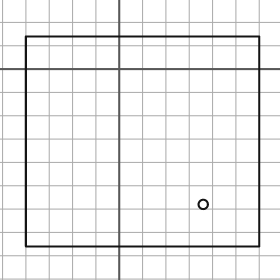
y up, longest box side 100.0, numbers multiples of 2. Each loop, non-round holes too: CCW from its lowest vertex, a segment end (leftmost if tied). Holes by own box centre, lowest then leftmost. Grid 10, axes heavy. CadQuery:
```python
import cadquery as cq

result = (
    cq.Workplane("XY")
    .moveTo(-40.0, -76.0)
    .lineTo(60.0, -76.0)
    .lineTo(60.0, 14.0)
    .lineTo(-40.0, 14.0)
    .close()
    .moveTo(36.0, -58.0)
    .circle(2.0)
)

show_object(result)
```